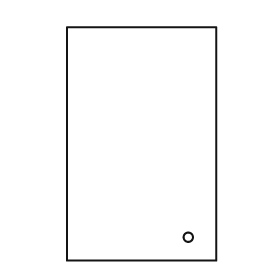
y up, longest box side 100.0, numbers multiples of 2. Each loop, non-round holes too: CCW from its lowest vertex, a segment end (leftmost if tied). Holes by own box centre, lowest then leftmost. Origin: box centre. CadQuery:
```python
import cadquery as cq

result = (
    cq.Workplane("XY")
    .moveTo(-32.0, -50.0)
    .lineTo(32.0, -50.0)
    .lineTo(32.0, 50.0)
    .lineTo(-32.0, 50.0)
    .close()
    .moveTo(20.0, -40.0)
    .circle(2.0)
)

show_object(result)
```